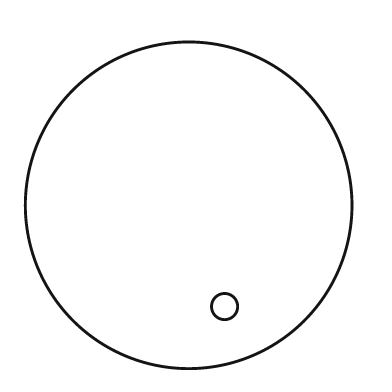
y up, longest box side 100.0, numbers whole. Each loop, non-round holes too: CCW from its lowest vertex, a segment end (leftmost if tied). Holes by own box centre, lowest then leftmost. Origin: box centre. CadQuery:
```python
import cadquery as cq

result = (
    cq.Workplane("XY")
    .moveTo(0.0, 0.0)
    .circle(50.0)
    .moveTo(11.0, -31.0)
    .circle(4.0)
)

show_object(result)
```